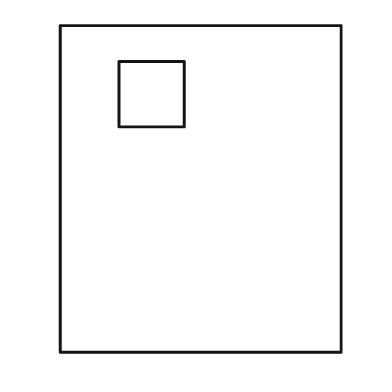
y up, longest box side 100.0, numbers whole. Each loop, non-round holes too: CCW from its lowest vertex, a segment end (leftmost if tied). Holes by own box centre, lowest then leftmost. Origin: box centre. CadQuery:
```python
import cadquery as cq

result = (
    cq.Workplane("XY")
    .moveTo(-43.0, -50.0)
    .lineTo(43.0, -50.0)
    .lineTo(43.0, 50.0)
    .lineTo(-43.0, 50.0)
    .close()
    .moveTo(-25.0, 19.0)
    .lineTo(-5.0, 19.0)
    .lineTo(-5.0, 39.0)
    .lineTo(-25.0, 39.0)
    .close()
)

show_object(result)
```